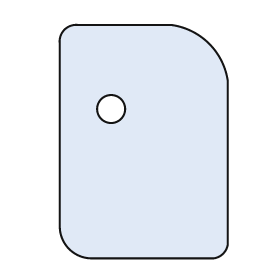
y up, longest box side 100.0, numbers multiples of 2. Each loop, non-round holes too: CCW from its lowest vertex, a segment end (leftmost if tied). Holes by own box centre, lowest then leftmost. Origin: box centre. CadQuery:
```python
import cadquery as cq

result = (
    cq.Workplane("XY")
    .moveTo(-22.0, -50.0)
    .lineTo(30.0, -50.0)
    .threePointArc((34.0, -48.0), (36.0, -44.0))
    .lineTo(36.0, 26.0)
    .threePointArc((28.0, 42.0), (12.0, 50.0))
    .lineTo(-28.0, 50.0)
    .threePointArc((-34.0, 48.0), (-36.0, 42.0))
    .lineTo(-36.0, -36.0)
    .threePointArc((-32.0, -46.0), (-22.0, -50.0))
    .close()
    .moveTo(-14.0, 14.0)
    .circle(6.0)
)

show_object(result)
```